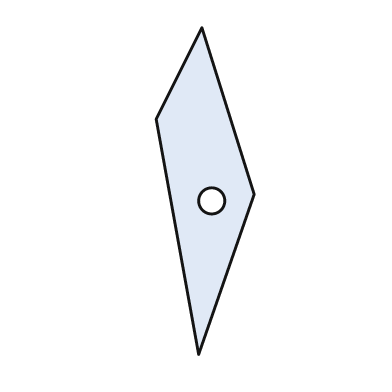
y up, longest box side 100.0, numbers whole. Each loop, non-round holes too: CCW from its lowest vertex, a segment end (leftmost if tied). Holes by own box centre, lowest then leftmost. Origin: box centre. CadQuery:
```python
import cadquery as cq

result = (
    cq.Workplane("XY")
    .moveTo(-2.0, -50.0)
    .lineTo(15.0, -1.0)
    .lineTo(-1.0, 50.0)
    .lineTo(-15.0, 22.0)
    .close()
    .moveTo(2.0, -3.0)
    .circle(4.0)
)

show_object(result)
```